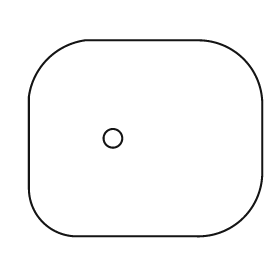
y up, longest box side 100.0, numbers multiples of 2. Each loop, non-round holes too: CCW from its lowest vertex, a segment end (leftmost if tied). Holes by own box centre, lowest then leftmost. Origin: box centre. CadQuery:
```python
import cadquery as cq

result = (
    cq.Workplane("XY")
    .moveTo(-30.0, -42.0)
    .lineTo(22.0, -42.0)
    .threePointArc((42.0, -34.0), (50.0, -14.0))
    .lineTo(50.0, 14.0)
    .threePointArc((42.0, 34.0), (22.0, 42.0))
    .lineTo(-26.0, 42.0)
    .threePointArc((-42.0, 34.0), (-50.0, 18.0))
    .lineTo(-50.0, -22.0)
    .threePointArc((-44.0, -36.0), (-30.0, -42.0))
    .close()
    .moveTo(-14.0, 0.0)
    .circle(4.0)
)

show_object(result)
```